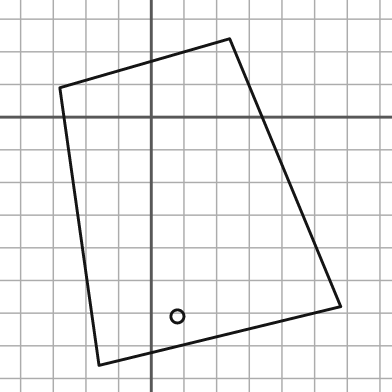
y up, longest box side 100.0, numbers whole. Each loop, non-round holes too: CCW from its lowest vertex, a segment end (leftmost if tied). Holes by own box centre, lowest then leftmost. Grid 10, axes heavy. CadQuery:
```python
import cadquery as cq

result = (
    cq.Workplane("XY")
    .moveTo(-16.0, -76.0)
    .lineTo(58.0, -58.0)
    .lineTo(24.0, 24.0)
    .lineTo(-28.0, 9.0)
    .close()
    .moveTo(8.0, -61.0)
    .circle(2.0)
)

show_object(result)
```